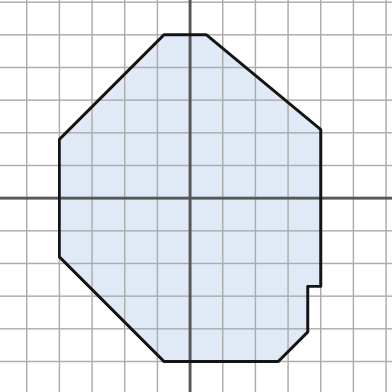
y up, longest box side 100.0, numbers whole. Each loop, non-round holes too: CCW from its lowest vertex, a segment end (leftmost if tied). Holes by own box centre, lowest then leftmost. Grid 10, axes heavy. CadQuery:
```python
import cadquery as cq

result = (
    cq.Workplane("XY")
    .moveTo(-8.0, -50.0)
    .lineTo(27.0, -50.0)
    .lineTo(36.0, -41.0)
    .lineTo(36.0, -27.0)
    .lineTo(40.0, -27.0)
    .lineTo(40.0, 21.0)
    .lineTo(5.0, 50.0)
    .lineTo(-8.0, 50.0)
    .lineTo(-40.0, 18.0)
    .lineTo(-40.0, -18.0)
    .close()
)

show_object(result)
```